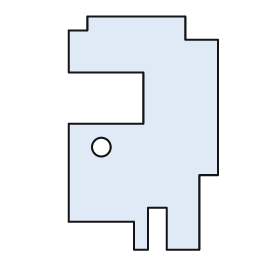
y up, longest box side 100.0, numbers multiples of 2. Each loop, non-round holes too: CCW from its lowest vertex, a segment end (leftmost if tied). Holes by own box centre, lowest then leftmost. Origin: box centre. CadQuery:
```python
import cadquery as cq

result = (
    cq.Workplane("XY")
    .moveTo(-4.0, -50.0)
    .lineTo(2.0, -50.0)
    .lineTo(2.0, -32.0)
    .lineTo(10.0, -32.0)
    .lineTo(10.0, -50.0)
    .lineTo(24.0, -50.0)
    .lineTo(24.0, -18.0)
    .lineTo(32.0, -18.0)
    .lineTo(32.0, 40.0)
    .lineTo(18.0, 40.0)
    .lineTo(18.0, 50.0)
    .lineTo(-24.0, 50.0)
    .lineTo(-24.0, 44.0)
    .lineTo(-32.0, 44.0)
    .lineTo(-32.0, 26.0)
    .lineTo(0.0, 26.0)
    .lineTo(0.0, 4.0)
    .lineTo(-32.0, 4.0)
    .lineTo(-32.0, -38.0)
    .lineTo(-4.0, -38.0)
    .close()
    .moveTo(-18.0, -6.0)
    .circle(4.0)
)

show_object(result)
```